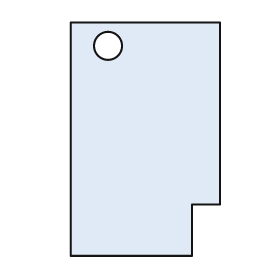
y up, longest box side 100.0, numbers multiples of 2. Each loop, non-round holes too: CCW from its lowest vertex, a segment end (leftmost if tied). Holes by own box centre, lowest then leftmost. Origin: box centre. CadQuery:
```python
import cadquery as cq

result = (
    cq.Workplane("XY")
    .moveTo(-32.0, -50.0)
    .lineTo(20.0, -50.0)
    .lineTo(20.0, -28.0)
    .lineTo(32.0, -28.0)
    .lineTo(32.0, 50.0)
    .lineTo(-32.0, 50.0)
    .close()
    .moveTo(-16.0, 40.0)
    .circle(6.0)
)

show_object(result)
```